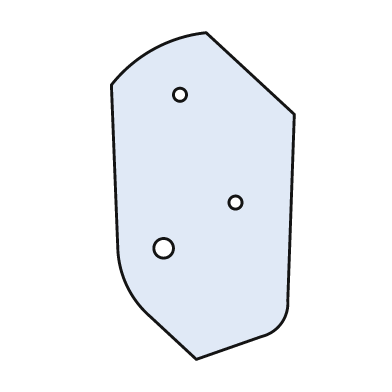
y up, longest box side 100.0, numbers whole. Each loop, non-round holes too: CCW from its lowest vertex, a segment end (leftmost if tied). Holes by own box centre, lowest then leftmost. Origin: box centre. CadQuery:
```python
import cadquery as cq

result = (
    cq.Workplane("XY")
    .moveTo(-2.0, -50.0)
    .lineTo(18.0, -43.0)
    .threePointArc((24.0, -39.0), (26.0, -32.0))
    .lineTo(28.0, 25.0)
    .lineTo(1.0, 50.0)
    .threePointArc((-15.0, 45.0), (-28.0, 34.0))
    .lineTo(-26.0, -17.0)
    .threePointArc((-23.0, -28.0), (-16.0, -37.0))
    .close()
    .moveTo(-12.0, -16.0)
    .circle(3.0)
    .moveTo(10.0, -2.0)
    .circle(2.0)
    .moveTo(-7.0, 31.0)
    .circle(2.0)
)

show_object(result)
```